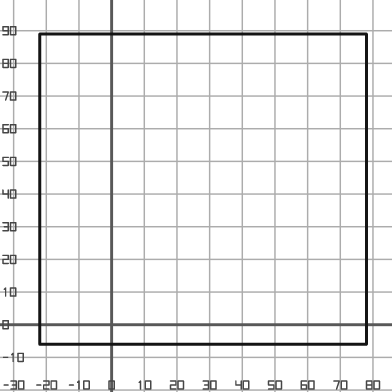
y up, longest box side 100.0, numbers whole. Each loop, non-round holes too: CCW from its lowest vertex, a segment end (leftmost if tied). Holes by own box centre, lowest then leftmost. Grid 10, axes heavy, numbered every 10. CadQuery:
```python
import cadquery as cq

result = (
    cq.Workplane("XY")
    .moveTo(-22.0, -6.0)
    .lineTo(78.0, -6.0)
    .lineTo(78.0, 89.0)
    .lineTo(-22.0, 89.0)
    .close()
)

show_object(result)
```